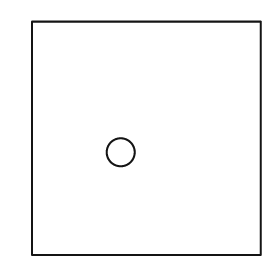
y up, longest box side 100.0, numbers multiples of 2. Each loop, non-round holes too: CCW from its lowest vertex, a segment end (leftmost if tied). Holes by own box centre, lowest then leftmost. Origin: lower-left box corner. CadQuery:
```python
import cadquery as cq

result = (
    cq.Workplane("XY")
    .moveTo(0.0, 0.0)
    .lineTo(98.0, 0.0)
    .lineTo(98.0, 100.0)
    .lineTo(0.0, 100.0)
    .close()
    .moveTo(38.0, 44.0)
    .circle(6.0)
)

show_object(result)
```